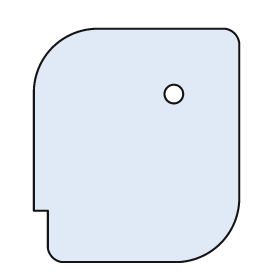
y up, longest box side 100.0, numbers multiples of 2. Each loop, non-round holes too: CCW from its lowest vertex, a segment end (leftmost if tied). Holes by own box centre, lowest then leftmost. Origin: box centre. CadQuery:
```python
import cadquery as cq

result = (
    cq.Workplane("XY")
    .moveTo(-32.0, -50.0)
    .lineTo(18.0, -50.0)
    .threePointArc((36.0, -42.0), (44.0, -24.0))
    .lineTo(44.0, 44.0)
    .threePointArc((42.0, 48.0), (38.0, 50.0))
    .lineTo(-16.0, 50.0)
    .threePointArc((-36.0, 42.0), (-44.0, 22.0))
    .lineTo(-44.0, -28.0)
    .lineTo(-38.0, -28.0)
    .lineTo(-38.0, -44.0)
    .threePointArc((-36.0, -48.0), (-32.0, -50.0))
    .close()
    .moveTo(16.0, 22.0)
    .circle(4.0)
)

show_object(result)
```